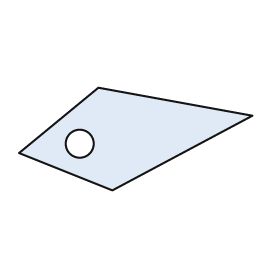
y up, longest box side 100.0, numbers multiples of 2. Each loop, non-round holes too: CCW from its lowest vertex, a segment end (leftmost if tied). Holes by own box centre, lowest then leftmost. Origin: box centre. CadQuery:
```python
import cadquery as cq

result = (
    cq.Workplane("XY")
    .moveTo(-10.0, -22.0)
    .lineTo(50.0, 10.0)
    .lineTo(-16.0, 22.0)
    .lineTo(-50.0, -6.0)
    .close()
    .moveTo(-24.0, -2.0)
    .circle(6.0)
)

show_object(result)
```